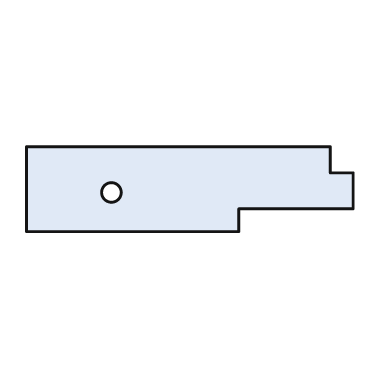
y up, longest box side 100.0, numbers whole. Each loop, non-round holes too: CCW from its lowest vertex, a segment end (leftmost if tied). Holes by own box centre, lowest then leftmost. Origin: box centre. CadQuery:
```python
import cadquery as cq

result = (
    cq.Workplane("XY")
    .moveTo(-50.0, -13.0)
    .lineTo(15.0, -13.0)
    .lineTo(15.0, -6.0)
    .lineTo(50.0, -6.0)
    .lineTo(50.0, 5.0)
    .lineTo(43.0, 5.0)
    .lineTo(43.0, 13.0)
    .lineTo(-50.0, 13.0)
    .close()
    .moveTo(-24.0, -1.0)
    .circle(3.0)
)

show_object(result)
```